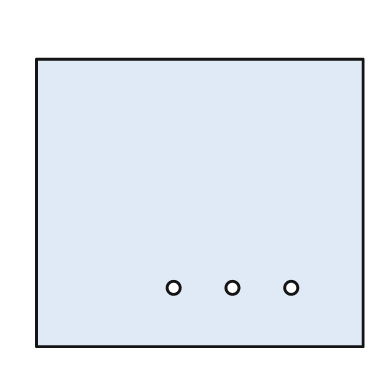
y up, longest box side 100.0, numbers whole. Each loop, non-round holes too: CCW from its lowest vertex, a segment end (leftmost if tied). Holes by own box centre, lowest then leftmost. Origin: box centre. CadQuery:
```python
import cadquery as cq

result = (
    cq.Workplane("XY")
    .moveTo(-50.0, -44.0)
    .lineTo(50.0, -44.0)
    .lineTo(50.0, 44.0)
    .lineTo(-50.0, 44.0)
    .close()
    .moveTo(-8.0, -26.0)
    .circle(2.0)
    .moveTo(10.0, -26.0)
    .circle(2.0)
    .moveTo(28.0, -26.0)
    .circle(2.0)
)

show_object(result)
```